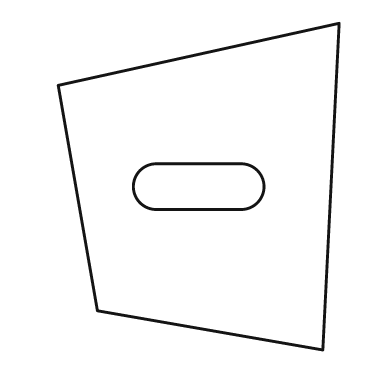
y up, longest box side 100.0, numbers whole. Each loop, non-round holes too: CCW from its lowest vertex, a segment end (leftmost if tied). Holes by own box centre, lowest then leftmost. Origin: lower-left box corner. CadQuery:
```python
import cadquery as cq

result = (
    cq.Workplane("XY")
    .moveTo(81.0, 0.0)
    .lineTo(86.0, 100.0)
    .lineTo(0.0, 81.0)
    .lineTo(12.0, 12.0)
    .close()
    .moveTo(30.0, 43.0)
    .lineTo(56.0, 43.0)
    .threePointArc((63.0, 50.0), (56.0, 57.0))
    .lineTo(30.0, 57.0)
    .threePointArc((23.0, 50.0), (30.0, 43.0))
    .close()
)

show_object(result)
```